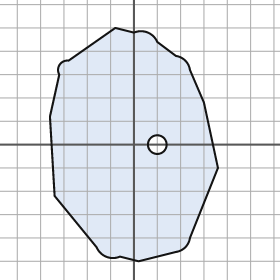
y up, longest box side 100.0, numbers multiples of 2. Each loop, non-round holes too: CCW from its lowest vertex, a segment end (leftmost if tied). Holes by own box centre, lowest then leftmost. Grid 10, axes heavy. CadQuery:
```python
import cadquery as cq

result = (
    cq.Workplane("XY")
    .moveTo(2.0, -50.0)
    .lineTo(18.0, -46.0)
    .threePointArc((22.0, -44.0), (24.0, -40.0))
    .lineTo(36.0, -10.0)
    .lineTo(30.0, 18.0)
    .lineTo(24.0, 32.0)
    .threePointArc((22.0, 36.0), (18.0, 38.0))
    .lineTo(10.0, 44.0)
    .threePointArc((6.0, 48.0), (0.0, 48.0))
    .lineTo(-8.0, 50.0)
    .lineTo(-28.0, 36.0)
    .threePointArc((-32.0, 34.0), (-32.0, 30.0))
    .lineTo(-36.0, 12.0)
    .lineTo(-34.0, -22.0)
    .lineTo(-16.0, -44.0)
    .threePointArc((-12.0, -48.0), (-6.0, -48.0))
    .close()
    .moveTo(10.0, 0.0)
    .circle(4.0)
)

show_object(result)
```